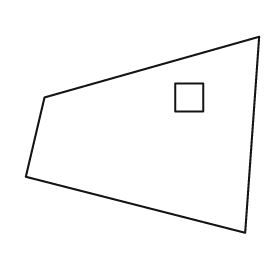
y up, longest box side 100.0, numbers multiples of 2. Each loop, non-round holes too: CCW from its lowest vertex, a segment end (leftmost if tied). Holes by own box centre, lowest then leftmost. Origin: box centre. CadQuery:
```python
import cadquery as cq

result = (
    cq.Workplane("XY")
    .moveTo(44.0, -42.0)
    .lineTo(50.0, 42.0)
    .lineTo(-42.0, 16.0)
    .lineTo(-50.0, -18.0)
    .close()
    .moveTo(14.0, 10.0)
    .lineTo(26.0, 10.0)
    .lineTo(26.0, 22.0)
    .lineTo(14.0, 22.0)
    .close()
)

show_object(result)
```